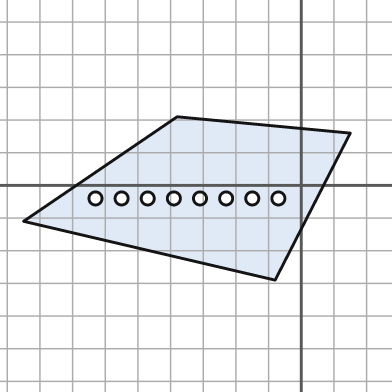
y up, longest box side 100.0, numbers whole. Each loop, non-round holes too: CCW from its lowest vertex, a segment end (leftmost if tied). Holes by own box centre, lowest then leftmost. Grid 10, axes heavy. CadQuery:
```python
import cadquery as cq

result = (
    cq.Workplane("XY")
    .moveTo(-8.0, -29.0)
    .lineTo(15.0, 16.0)
    .lineTo(-38.0, 21.0)
    .lineTo(-85.0, -11.0)
    .close()
    .moveTo(-63.0, -4.0)
    .circle(2.0)
    .moveTo(-55.0, -4.0)
    .circle(2.0)
    .moveTo(-47.0, -4.0)
    .circle(2.0)
    .moveTo(-39.0, -4.0)
    .circle(2.0)
    .moveTo(-31.0, -4.0)
    .circle(2.0)
    .moveTo(-23.0, -4.0)
    .circle(2.0)
    .moveTo(-15.0, -4.0)
    .circle(2.0)
    .moveTo(-7.0, -4.0)
    .circle(2.0)
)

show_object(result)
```